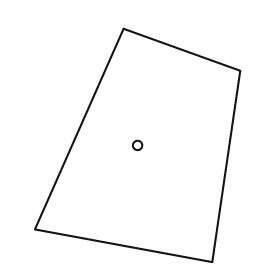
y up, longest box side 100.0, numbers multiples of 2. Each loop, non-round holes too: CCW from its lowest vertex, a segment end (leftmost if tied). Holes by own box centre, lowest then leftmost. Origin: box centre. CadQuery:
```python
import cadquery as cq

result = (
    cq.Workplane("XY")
    .moveTo(32.0, -50.0)
    .lineTo(44.0, 32.0)
    .lineTo(-6.0, 50.0)
    .lineTo(-44.0, -36.0)
    .close()
    .moveTo(0.0, 0.0)
    .circle(2.0)
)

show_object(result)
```